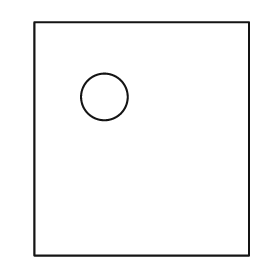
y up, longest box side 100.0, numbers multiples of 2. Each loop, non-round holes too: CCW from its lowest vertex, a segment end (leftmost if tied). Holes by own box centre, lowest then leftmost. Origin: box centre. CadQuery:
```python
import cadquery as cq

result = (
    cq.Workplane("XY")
    .moveTo(-46.0, -50.0)
    .lineTo(46.0, -50.0)
    .lineTo(46.0, 50.0)
    .lineTo(-46.0, 50.0)
    .close()
    .moveTo(-16.0, 18.0)
    .circle(10.0)
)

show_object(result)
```